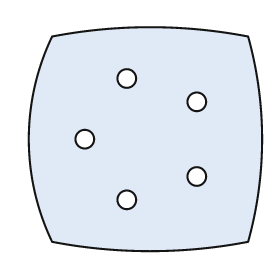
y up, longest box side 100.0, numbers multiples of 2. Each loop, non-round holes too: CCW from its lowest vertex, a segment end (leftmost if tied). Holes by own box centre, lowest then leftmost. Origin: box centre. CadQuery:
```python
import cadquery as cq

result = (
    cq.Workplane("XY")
    .moveTo(-40.0, -44.0)
    .threePointArc((2.0, -48.0), (44.0, -44.0))
    .threePointArc((50.0, 0.0), (44.0, 44.0))
    .threePointArc((2.0, 48.0), (-40.0, 44.0))
    .threePointArc((-50.0, 0.0), (-40.0, -44.0))
    .close()
    .moveTo(-8.0, -26.0)
    .circle(4.0)
    .moveTo(22.0, -16.0)
    .circle(4.0)
    .moveTo(-26.0, 0.0)
    .circle(4.0)
    .moveTo(22.0, 16.0)
    .circle(4.0)
    .moveTo(-8.0, 26.0)
    .circle(4.0)
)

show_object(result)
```